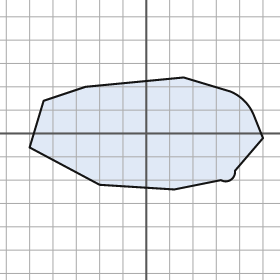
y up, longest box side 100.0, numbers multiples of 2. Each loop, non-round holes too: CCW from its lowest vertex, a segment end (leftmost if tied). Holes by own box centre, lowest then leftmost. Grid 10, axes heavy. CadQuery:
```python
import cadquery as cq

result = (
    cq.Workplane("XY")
    .moveTo(12.0, -24.0)
    .lineTo(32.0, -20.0)
    .threePointArc((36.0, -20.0), (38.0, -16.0))
    .lineTo(50.0, -2.0)
    .lineTo(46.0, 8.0)
    .threePointArc((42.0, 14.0), (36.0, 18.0))
    .lineTo(16.0, 24.0)
    .lineTo(-26.0, 20.0)
    .lineTo(-44.0, 14.0)
    .lineTo(-50.0, -6.0)
    .lineTo(-20.0, -22.0)
    .close()
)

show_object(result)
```